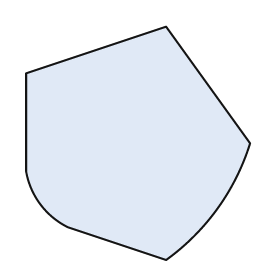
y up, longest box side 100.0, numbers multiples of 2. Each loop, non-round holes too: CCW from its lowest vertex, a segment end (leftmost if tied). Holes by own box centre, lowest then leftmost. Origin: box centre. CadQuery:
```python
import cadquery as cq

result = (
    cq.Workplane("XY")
    .moveTo(12.0, -50.0)
    .threePointArc((34.0, -28.0), (48.0, 0.0))
    .lineTo(12.0, 50.0)
    .lineTo(-48.0, 30.0)
    .lineTo(-48.0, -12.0)
    .threePointArc((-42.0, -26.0), (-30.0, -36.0))
    .close()
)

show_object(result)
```